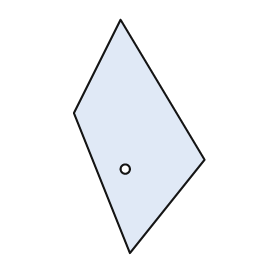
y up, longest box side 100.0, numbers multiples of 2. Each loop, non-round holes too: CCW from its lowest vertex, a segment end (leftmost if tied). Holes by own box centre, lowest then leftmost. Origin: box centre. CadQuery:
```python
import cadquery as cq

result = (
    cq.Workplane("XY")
    .moveTo(-4.0, -50.0)
    .lineTo(28.0, -10.0)
    .lineTo(-8.0, 50.0)
    .lineTo(-28.0, 10.0)
    .close()
    .moveTo(-6.0, -14.0)
    .circle(2.0)
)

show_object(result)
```